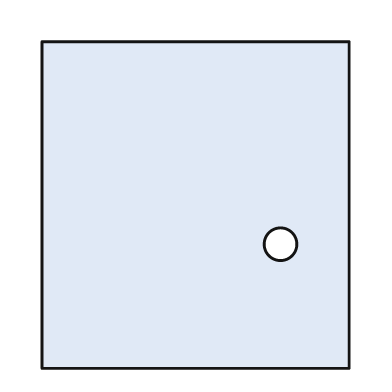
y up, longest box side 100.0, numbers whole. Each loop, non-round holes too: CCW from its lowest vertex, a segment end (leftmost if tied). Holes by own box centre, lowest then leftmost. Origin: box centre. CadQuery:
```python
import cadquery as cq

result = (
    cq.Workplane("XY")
    .moveTo(-47.0, -50.0)
    .lineTo(47.0, -50.0)
    .lineTo(47.0, 50.0)
    .lineTo(-47.0, 50.0)
    .close()
    .moveTo(26.0, -12.0)
    .circle(5.0)
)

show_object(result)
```